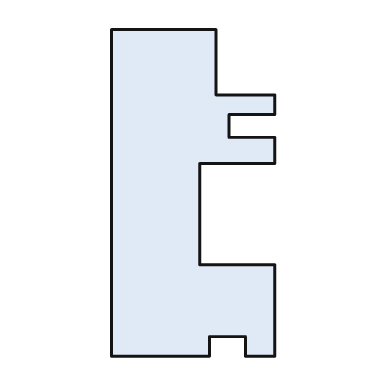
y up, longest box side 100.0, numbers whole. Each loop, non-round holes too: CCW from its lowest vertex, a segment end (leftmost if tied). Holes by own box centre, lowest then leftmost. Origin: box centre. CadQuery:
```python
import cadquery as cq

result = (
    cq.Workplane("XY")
    .moveTo(-25.0, -50.0)
    .lineTo(5.0, -50.0)
    .lineTo(5.0, -44.0)
    .lineTo(16.0, -44.0)
    .lineTo(16.0, -50.0)
    .lineTo(25.0, -50.0)
    .lineTo(25.0, -22.0)
    .lineTo(2.0, -22.0)
    .lineTo(2.0, 9.0)
    .lineTo(25.0, 9.0)
    .lineTo(25.0, 17.0)
    .lineTo(11.0, 17.0)
    .lineTo(11.0, 24.0)
    .lineTo(25.0, 24.0)
    .lineTo(25.0, 30.0)
    .lineTo(7.0, 30.0)
    .lineTo(7.0, 50.0)
    .lineTo(-25.0, 50.0)
    .close()
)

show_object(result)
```